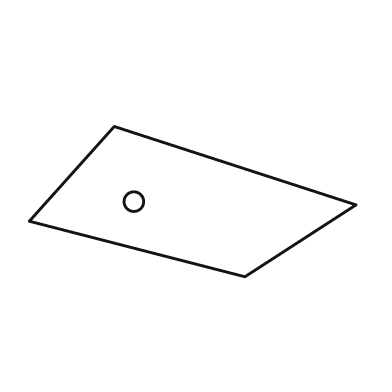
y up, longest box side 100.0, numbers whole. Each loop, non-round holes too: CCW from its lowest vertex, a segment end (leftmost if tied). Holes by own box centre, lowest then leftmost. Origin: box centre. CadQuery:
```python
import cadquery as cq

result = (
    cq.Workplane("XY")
    .moveTo(16.0, -23.0)
    .lineTo(50.0, -1.0)
    .lineTo(-24.0, 23.0)
    .lineTo(-50.0, -6.0)
    .close()
    .moveTo(-18.0, 0.0)
    .circle(3.0)
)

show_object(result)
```